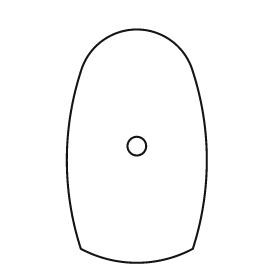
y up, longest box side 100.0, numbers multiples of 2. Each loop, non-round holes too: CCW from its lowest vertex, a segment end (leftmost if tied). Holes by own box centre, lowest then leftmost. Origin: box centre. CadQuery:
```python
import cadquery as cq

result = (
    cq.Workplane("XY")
    .moveTo(-24.0, -44.0)
    .threePointArc((0.0, -50.0), (24.0, -44.0))
    .threePointArc((30.0, -6.0), (24.0, 32.0))
    .threePointArc((0.0, 50.0), (-24.0, 32.0))
    .threePointArc((-30.0, -6.0), (-24.0, -44.0))
    .close()
    .moveTo(0.0, 0.0)
    .circle(4.0)
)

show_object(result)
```